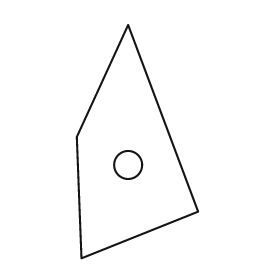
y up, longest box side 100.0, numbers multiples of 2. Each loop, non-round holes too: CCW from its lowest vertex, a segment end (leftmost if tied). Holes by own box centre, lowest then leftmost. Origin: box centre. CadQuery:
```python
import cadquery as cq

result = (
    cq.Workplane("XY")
    .moveTo(-24.0, -50.0)
    .lineTo(26.0, -30.0)
    .lineTo(-4.0, 50.0)
    .lineTo(-26.0, 2.0)
    .close()
    .moveTo(-4.0, -10.0)
    .circle(6.0)
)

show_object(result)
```